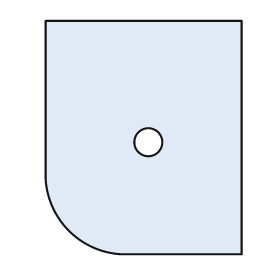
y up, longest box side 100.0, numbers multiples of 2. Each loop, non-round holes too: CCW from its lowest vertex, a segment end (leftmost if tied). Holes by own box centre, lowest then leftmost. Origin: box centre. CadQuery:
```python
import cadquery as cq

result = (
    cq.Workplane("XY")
    .moveTo(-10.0, -50.0)
    .lineTo(42.0, -50.0)
    .lineTo(42.0, 50.0)
    .lineTo(-42.0, 50.0)
    .lineTo(-42.0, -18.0)
    .threePointArc((-32.0, -40.0), (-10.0, -50.0))
    .close()
    .moveTo(2.0, -2.0)
    .circle(6.0)
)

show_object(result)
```